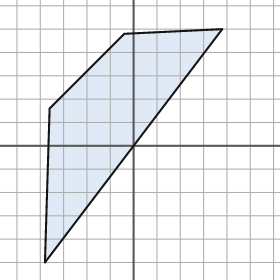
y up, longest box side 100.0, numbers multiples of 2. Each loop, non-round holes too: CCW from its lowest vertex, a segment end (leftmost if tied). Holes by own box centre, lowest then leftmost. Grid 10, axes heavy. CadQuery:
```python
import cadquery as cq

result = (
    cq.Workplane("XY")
    .moveTo(-38.0, -50.0)
    .lineTo(38.0, 50.0)
    .lineTo(-4.0, 48.0)
    .lineTo(-36.0, 16.0)
    .close()
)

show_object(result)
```